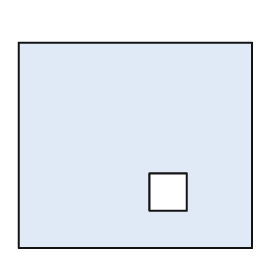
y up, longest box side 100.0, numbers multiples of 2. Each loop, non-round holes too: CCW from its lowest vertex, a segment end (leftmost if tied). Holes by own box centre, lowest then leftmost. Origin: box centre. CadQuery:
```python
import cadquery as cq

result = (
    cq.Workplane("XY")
    .moveTo(-50.0, -44.0)
    .lineTo(50.0, -44.0)
    .lineTo(50.0, 44.0)
    .lineTo(-50.0, 44.0)
    .close()
    .moveTo(6.0, -28.0)
    .lineTo(22.0, -28.0)
    .lineTo(22.0, -12.0)
    .lineTo(6.0, -12.0)
    .close()
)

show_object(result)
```